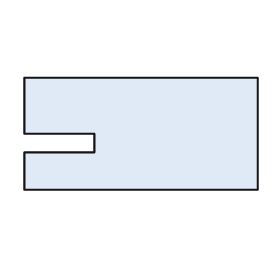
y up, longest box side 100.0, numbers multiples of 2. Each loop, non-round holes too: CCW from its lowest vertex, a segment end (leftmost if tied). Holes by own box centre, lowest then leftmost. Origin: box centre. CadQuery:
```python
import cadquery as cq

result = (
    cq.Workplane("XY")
    .moveTo(-50.0, -24.0)
    .lineTo(50.0, -24.0)
    .lineTo(50.0, 24.0)
    .lineTo(-50.0, 24.0)
    .lineTo(-50.0, 0.0)
    .lineTo(-20.0, 0.0)
    .lineTo(-20.0, -8.0)
    .lineTo(-50.0, -8.0)
    .close()
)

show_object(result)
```